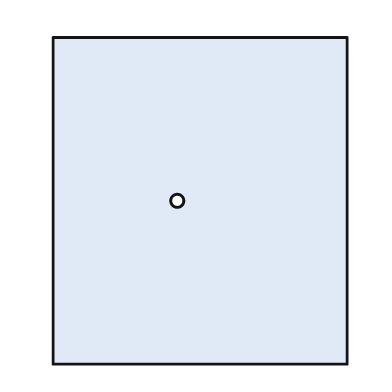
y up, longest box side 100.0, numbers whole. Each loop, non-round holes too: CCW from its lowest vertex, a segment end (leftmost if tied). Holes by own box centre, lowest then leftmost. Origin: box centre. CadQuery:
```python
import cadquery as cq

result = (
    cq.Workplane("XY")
    .moveTo(-45.0, -50.0)
    .lineTo(45.0, -50.0)
    .lineTo(45.0, 50.0)
    .lineTo(-45.0, 50.0)
    .close()
    .moveTo(-7.0, 0.0)
    .circle(2.0)
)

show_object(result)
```